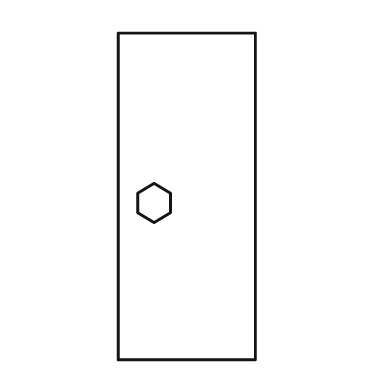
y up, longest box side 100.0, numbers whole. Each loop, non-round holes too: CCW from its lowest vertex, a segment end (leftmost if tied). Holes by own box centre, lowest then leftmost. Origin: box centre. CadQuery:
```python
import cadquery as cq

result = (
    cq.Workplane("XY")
    .moveTo(-21.0, -50.0)
    .lineTo(21.0, -50.0)
    .lineTo(21.0, 50.0)
    .lineTo(-21.0, 50.0)
    .close()
    .moveTo(-10.0, -8.0)
    .lineTo(-5.0, -5.0)
    .lineTo(-5.0, 1.0)
    .lineTo(-10.0, 4.0)
    .lineTo(-15.0, 1.0)
    .lineTo(-15.0, -5.0)
    .close()
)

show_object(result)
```